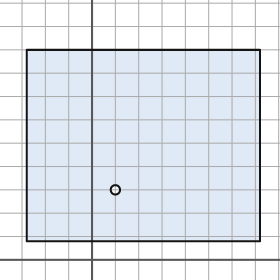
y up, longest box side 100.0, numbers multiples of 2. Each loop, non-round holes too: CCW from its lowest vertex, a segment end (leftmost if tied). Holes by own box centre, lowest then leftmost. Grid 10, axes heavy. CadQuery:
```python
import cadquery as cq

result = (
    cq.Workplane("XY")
    .moveTo(-28.0, 8.0)
    .lineTo(72.0, 8.0)
    .lineTo(72.0, 90.0)
    .lineTo(-28.0, 90.0)
    .close()
    .moveTo(10.0, 30.0)
    .circle(2.0)
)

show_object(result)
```